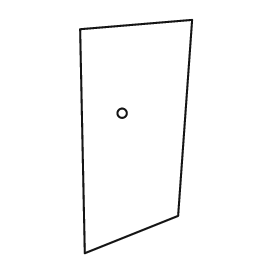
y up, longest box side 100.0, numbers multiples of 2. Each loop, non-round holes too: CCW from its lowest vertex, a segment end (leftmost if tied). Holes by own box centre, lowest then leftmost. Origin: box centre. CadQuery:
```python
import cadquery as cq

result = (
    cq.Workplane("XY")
    .moveTo(-22.0, -50.0)
    .lineTo(18.0, -34.0)
    .lineTo(24.0, 50.0)
    .lineTo(-24.0, 46.0)
    .close()
    .moveTo(-6.0, 10.0)
    .circle(2.0)
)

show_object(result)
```